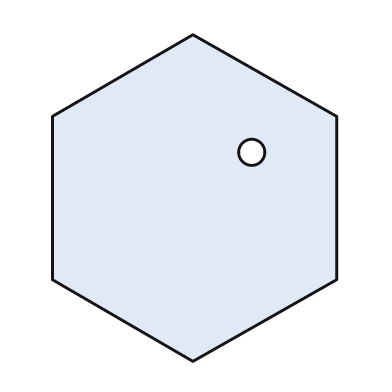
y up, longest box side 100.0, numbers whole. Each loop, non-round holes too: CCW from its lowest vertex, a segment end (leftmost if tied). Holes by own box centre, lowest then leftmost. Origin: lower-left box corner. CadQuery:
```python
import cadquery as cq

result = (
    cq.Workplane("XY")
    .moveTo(43.0, 0.0)
    .lineTo(87.0, 25.0)
    .lineTo(87.0, 75.0)
    .lineTo(43.0, 100.0)
    .lineTo(0.0, 75.0)
    .lineTo(0.0, 25.0)
    .close()
    .moveTo(61.0, 64.0)
    .circle(4.0)
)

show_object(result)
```